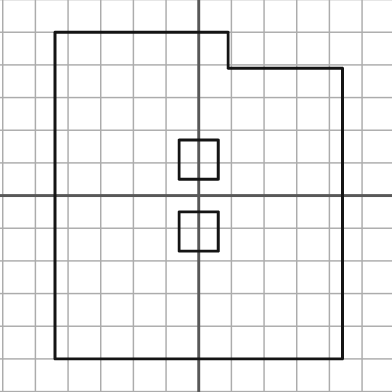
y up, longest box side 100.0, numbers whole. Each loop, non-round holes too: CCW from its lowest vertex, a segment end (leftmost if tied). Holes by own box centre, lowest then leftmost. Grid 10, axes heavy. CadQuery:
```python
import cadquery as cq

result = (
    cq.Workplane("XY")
    .moveTo(-44.0, -50.0)
    .lineTo(44.0, -50.0)
    .lineTo(44.0, 39.0)
    .lineTo(9.0, 39.0)
    .lineTo(9.0, 50.0)
    .lineTo(-44.0, 50.0)
    .close()
    .moveTo(-6.0, -17.0)
    .lineTo(6.0, -17.0)
    .lineTo(6.0, -5.0)
    .lineTo(-6.0, -5.0)
    .close()
    .moveTo(-6.0, 5.0)
    .lineTo(6.0, 5.0)
    .lineTo(6.0, 17.0)
    .lineTo(-6.0, 17.0)
    .close()
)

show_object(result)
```